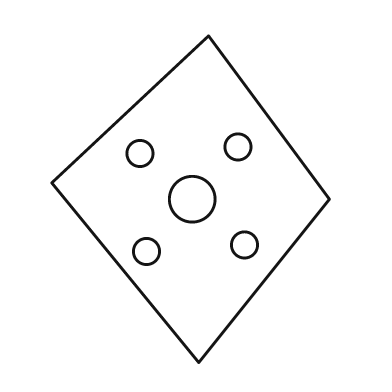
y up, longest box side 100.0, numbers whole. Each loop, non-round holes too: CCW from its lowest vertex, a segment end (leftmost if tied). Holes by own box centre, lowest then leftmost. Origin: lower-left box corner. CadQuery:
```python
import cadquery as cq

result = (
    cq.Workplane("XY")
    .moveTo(45.0, 0.0)
    .lineTo(85.0, 50.0)
    .lineTo(48.0, 100.0)
    .lineTo(0.0, 55.0)
    .close()
    .moveTo(29.0, 34.0)
    .circle(4.0)
    .moveTo(59.0, 36.0)
    .circle(4.0)
    .moveTo(43.0, 50.0)
    .circle(7.0)
    .moveTo(27.0, 64.0)
    .circle(4.0)
    .moveTo(57.0, 66.0)
    .circle(4.0)
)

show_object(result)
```